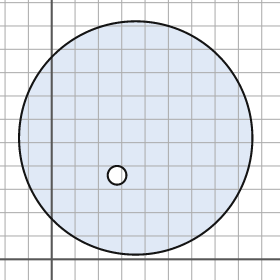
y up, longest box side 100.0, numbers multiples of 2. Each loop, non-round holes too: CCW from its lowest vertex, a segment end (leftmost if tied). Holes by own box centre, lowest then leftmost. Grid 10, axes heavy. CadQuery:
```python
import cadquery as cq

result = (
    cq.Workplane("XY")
    .moveTo(36.0, 52.0)
    .circle(50.0)
    .moveTo(28.0, 36.0)
    .circle(4.0)
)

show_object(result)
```